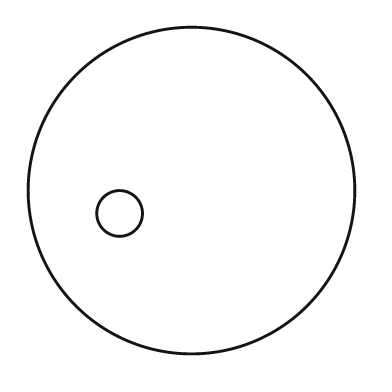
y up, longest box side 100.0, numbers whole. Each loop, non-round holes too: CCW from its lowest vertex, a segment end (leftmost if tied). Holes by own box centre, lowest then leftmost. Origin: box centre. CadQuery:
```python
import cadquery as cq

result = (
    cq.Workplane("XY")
    .moveTo(0.0, 0.0)
    .circle(50.0)
    .moveTo(-22.0, -7.0)
    .circle(7.0)
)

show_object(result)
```